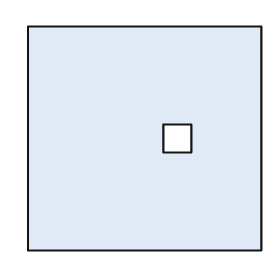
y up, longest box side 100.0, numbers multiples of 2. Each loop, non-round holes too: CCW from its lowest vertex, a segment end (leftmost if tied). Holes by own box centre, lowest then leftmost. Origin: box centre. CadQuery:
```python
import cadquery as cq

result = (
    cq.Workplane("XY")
    .moveTo(-50.0, -48.0)
    .lineTo(50.0, -48.0)
    .lineTo(50.0, 48.0)
    .lineTo(-50.0, 48.0)
    .close()
    .moveTo(8.0, -6.0)
    .lineTo(20.0, -6.0)
    .lineTo(20.0, 6.0)
    .lineTo(8.0, 6.0)
    .close()
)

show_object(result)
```